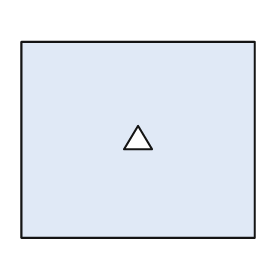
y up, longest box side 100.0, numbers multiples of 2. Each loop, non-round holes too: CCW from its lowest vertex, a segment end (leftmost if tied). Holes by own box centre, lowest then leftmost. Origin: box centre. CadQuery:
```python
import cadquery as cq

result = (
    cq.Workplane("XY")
    .moveTo(-50.0, -42.0)
    .lineTo(50.0, -42.0)
    .lineTo(50.0, 42.0)
    .lineTo(-50.0, 42.0)
    .close()
    .moveTo(-6.0, -4.0)
    .lineTo(6.0, -4.0)
    .lineTo(0.0, 6.0)
    .close()
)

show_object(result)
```